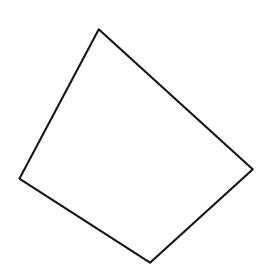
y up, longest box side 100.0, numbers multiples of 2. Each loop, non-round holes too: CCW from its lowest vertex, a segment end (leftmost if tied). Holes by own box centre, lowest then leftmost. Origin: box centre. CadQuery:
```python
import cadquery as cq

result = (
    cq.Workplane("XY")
    .moveTo(6.0, -50.0)
    .lineTo(50.0, -10.0)
    .lineTo(-16.0, 50.0)
    .lineTo(-50.0, -14.0)
    .close()
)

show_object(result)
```